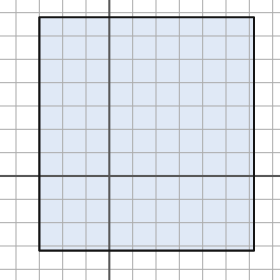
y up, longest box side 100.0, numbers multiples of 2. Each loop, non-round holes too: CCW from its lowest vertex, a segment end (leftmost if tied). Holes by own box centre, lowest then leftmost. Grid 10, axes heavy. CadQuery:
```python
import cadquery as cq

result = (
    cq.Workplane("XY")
    .moveTo(-30.0, -32.0)
    .lineTo(62.0, -32.0)
    .lineTo(62.0, 68.0)
    .lineTo(-30.0, 68.0)
    .close()
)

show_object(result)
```